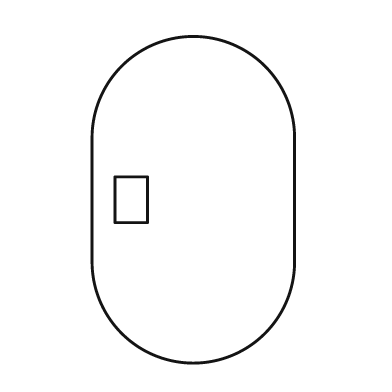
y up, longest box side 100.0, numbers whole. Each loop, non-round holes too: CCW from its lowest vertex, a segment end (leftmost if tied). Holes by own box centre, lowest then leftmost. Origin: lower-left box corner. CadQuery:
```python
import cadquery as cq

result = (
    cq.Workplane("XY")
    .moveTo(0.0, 31.0)
    .threePointArc((31.0, 0.0), (62.0, 31.0))
    .lineTo(62.0, 69.0)
    .threePointArc((31.0, 100.0), (0.0, 69.0))
    .close()
    .moveTo(7.0, 43.0)
    .lineTo(17.0, 43.0)
    .lineTo(17.0, 57.0)
    .lineTo(7.0, 57.0)
    .close()
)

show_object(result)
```